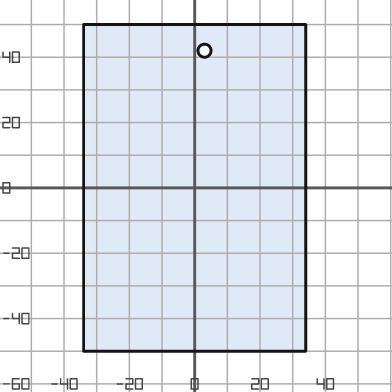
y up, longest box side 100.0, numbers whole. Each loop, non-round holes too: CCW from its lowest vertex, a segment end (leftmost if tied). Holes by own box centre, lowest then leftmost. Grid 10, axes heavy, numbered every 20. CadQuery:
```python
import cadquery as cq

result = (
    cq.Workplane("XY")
    .moveTo(-34.0, -50.0)
    .lineTo(34.0, -50.0)
    .lineTo(34.0, 50.0)
    .lineTo(-34.0, 50.0)
    .close()
    .moveTo(3.0, 42.0)
    .circle(2.0)
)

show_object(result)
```